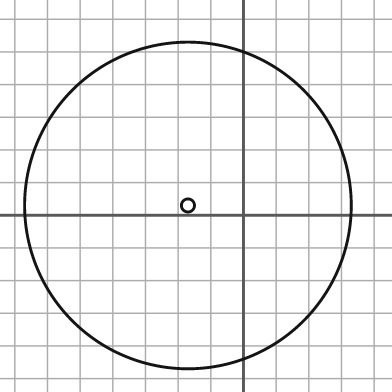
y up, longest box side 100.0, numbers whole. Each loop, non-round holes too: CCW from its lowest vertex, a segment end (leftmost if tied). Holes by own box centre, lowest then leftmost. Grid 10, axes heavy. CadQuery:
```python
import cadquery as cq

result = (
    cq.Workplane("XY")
    .moveTo(-17.0, 3.0)
    .circle(50.0)
    .moveTo(-17.0, 3.0)
    .circle(2.0)
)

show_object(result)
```